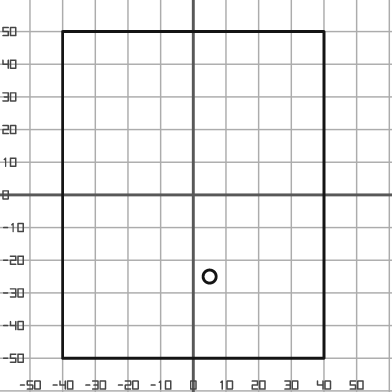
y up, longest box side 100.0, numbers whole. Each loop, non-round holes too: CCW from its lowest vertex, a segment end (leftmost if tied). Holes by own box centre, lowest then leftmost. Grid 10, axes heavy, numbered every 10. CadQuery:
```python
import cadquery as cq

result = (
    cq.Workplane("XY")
    .moveTo(-40.0, -50.0)
    .lineTo(40.0, -50.0)
    .lineTo(40.0, 50.0)
    .lineTo(-40.0, 50.0)
    .close()
    .moveTo(5.0, -25.0)
    .circle(2.0)
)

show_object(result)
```